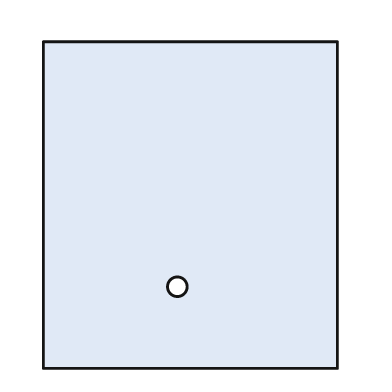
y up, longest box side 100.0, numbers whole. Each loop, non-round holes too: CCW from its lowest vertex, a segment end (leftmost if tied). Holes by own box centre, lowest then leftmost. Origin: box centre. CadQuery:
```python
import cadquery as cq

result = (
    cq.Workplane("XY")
    .moveTo(-45.0, -50.0)
    .lineTo(45.0, -50.0)
    .lineTo(45.0, 50.0)
    .lineTo(-45.0, 50.0)
    .close()
    .moveTo(-4.0, -25.0)
    .circle(3.0)
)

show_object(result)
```